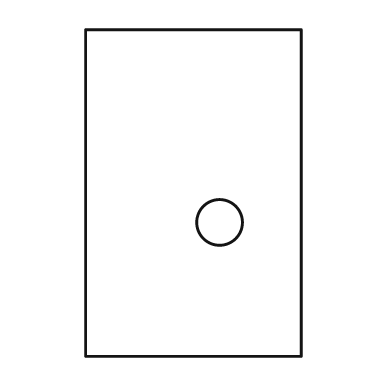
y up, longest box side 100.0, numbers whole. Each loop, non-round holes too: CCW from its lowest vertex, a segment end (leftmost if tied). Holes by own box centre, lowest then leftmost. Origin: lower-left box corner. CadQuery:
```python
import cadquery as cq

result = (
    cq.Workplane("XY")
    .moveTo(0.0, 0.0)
    .lineTo(66.0, 0.0)
    .lineTo(66.0, 100.0)
    .lineTo(0.0, 100.0)
    .close()
    .moveTo(41.0, 41.0)
    .circle(7.0)
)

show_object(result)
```